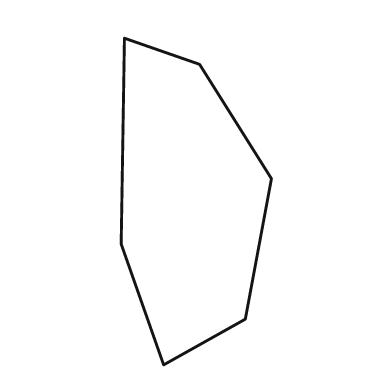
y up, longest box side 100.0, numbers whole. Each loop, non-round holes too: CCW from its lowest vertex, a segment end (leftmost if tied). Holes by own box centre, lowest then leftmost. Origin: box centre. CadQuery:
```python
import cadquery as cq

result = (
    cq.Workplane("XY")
    .moveTo(-10.0, -50.0)
    .lineTo(15.0, -36.0)
    .lineTo(23.0, 7.0)
    .lineTo(1.0, 42.0)
    .lineTo(-22.0, 50.0)
    .lineTo(-23.0, -13.0)
    .close()
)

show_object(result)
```